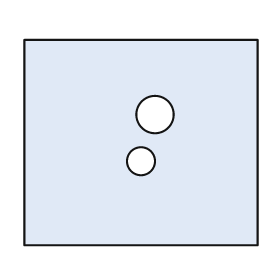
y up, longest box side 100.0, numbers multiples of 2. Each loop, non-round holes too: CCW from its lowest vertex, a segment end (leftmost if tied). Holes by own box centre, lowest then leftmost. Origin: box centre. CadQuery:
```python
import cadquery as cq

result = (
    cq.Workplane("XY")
    .moveTo(-50.0, -44.0)
    .lineTo(50.0, -44.0)
    .lineTo(50.0, 44.0)
    .lineTo(-50.0, 44.0)
    .close()
    .moveTo(0.0, -8.0)
    .circle(6.0)
    .moveTo(6.0, 12.0)
    .circle(8.0)
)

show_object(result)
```